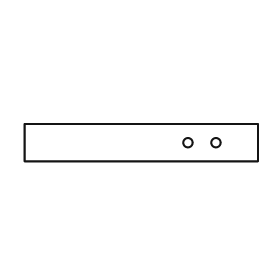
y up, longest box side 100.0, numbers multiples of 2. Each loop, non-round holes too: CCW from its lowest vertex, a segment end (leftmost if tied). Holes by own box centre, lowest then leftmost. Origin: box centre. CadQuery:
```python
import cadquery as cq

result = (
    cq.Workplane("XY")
    .moveTo(-50.0, -8.0)
    .lineTo(50.0, -8.0)
    .lineTo(50.0, 8.0)
    .lineTo(-50.0, 8.0)
    .close()
    .moveTo(20.0, 0.0)
    .circle(2.0)
    .moveTo(32.0, 0.0)
    .circle(2.0)
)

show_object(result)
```